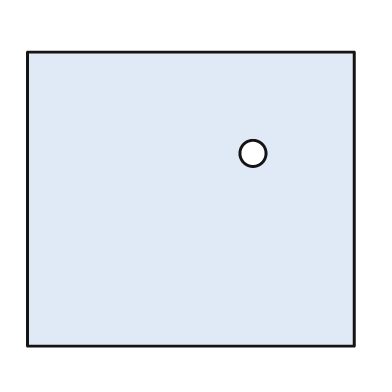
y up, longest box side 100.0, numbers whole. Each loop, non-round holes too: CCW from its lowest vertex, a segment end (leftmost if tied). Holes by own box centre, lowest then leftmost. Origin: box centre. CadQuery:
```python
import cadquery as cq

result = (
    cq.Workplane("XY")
    .moveTo(-50.0, -45.0)
    .lineTo(50.0, -45.0)
    .lineTo(50.0, 45.0)
    .lineTo(-50.0, 45.0)
    .close()
    .moveTo(19.0, 14.0)
    .circle(4.0)
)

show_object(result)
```